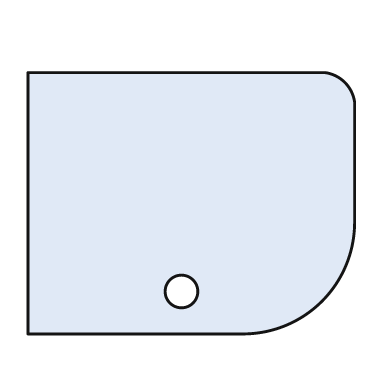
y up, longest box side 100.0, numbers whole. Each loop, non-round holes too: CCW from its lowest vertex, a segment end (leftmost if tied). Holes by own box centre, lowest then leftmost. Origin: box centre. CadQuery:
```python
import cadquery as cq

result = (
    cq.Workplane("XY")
    .moveTo(-50.0, -40.0)
    .lineTo(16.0, -40.0)
    .threePointArc((40.0, -30.0), (50.0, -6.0))
    .lineTo(50.0, 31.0)
    .threePointArc((47.0, 37.0), (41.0, 40.0))
    .lineTo(-50.0, 40.0)
    .close()
    .moveTo(-3.0, -27.0)
    .circle(5.0)
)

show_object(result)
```